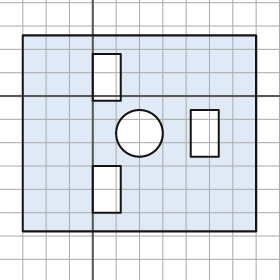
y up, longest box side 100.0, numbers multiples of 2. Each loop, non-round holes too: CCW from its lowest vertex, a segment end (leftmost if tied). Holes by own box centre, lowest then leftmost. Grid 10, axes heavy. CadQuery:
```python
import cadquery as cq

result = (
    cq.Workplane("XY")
    .moveTo(-30.0, -58.0)
    .lineTo(70.0, -58.0)
    .lineTo(70.0, 26.0)
    .lineTo(-30.0, 26.0)
    .close()
    .moveTo(0.0, -50.0)
    .lineTo(12.0, -50.0)
    .lineTo(12.0, -30.0)
    .lineTo(0.0, -30.0)
    .close()
    .moveTo(20.0, -16.0)
    .circle(10.0)
    .moveTo(42.0, -26.0)
    .lineTo(54.0, -26.0)
    .lineTo(54.0, -6.0)
    .lineTo(42.0, -6.0)
    .close()
    .moveTo(0.0, -2.0)
    .lineTo(12.0, -2.0)
    .lineTo(12.0, 18.0)
    .lineTo(0.0, 18.0)
    .close()
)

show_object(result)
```